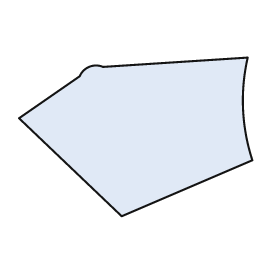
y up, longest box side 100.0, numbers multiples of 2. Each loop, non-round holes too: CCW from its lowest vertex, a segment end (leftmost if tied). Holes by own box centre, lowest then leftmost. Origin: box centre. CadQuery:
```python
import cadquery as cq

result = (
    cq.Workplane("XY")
    .moveTo(-6.0, -34.0)
    .lineTo(50.0, -10.0)
    .threePointArc((46.0, 12.0), (48.0, 34.0))
    .lineTo(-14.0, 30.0)
    .threePointArc((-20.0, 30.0), (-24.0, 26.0))
    .lineTo(-50.0, 8.0)
    .close()
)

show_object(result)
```